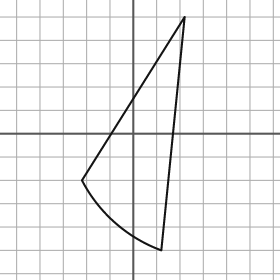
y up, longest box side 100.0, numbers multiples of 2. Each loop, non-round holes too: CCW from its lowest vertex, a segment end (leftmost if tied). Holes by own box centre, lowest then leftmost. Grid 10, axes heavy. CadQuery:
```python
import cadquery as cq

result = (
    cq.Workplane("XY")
    .moveTo(12.0, -50.0)
    .lineTo(22.0, 50.0)
    .lineTo(-22.0, -20.0)
    .threePointArc((-8.0, -38.0), (12.0, -50.0))
    .close()
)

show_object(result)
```